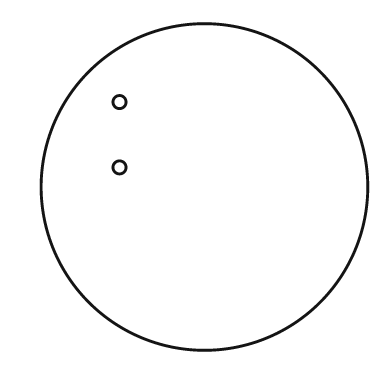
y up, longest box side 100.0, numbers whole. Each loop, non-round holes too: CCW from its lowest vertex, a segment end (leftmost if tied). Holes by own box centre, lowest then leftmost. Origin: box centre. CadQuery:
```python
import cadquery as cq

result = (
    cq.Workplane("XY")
    .moveTo(0.0, 0.0)
    .circle(50.0)
    .moveTo(-26.0, 6.0)
    .circle(2.0)
    .moveTo(-26.0, 26.0)
    .circle(2.0)
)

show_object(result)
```